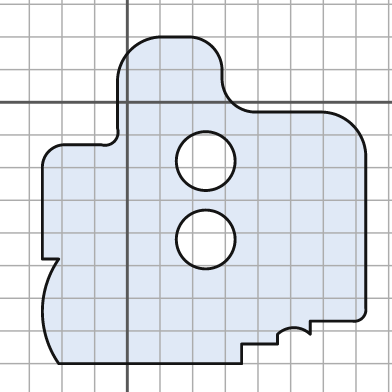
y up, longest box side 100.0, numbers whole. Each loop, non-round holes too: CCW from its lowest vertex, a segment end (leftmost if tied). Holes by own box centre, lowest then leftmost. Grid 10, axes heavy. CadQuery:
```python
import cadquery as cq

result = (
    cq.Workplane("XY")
    .moveTo(-21.0, -80.0)
    .lineTo(35.0, -80.0)
    .lineTo(35.0, -74.0)
    .lineTo(46.0, -74.0)
    .lineTo(46.0, -71.0)
    .threePointArc((51.0, -69.0), (56.0, -71.0))
    .lineTo(56.0, -67.0)
    .lineTo(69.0, -67.0)
    .threePointArc((72.0, -66.0), (73.0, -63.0))
    .lineTo(73.0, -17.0)
    .threePointArc((69.0, -7.0), (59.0, -3.0))
    .lineTo(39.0, -3.0)
    .threePointArc((32.0, 0.0), (29.0, 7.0))
    .lineTo(29.0, 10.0)
    .threePointArc((26.0, 17.0), (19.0, 20.0))
    .lineTo(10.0, 20.0)
    .threePointArc((1.0, 16.0), (-3.0, 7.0))
    .lineTo(-3.0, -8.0)
    .threePointArc((-4.0, -12.0), (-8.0, -13.0))
    .lineTo(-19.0, -13.0)
    .threePointArc((-24.0, -15.0), (-26.0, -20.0))
    .lineTo(-26.0, -48.0)
    .lineTo(-21.0, -48.0)
    .threePointArc((-26.0, -64.0), (-21.0, -80.0))
    .close()
    .moveTo(24.0, -42.0)
    .circle(9.0)
    .moveTo(24.0, -18.0)
    .circle(9.0)
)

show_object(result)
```